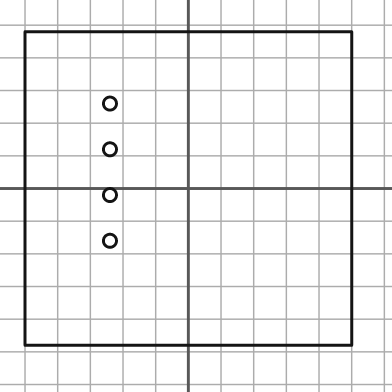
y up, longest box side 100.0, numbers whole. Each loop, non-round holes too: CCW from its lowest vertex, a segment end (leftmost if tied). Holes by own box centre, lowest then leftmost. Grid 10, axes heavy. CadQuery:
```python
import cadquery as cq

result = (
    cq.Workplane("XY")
    .moveTo(-50.0, -48.0)
    .lineTo(50.0, -48.0)
    .lineTo(50.0, 48.0)
    .lineTo(-50.0, 48.0)
    .close()
    .moveTo(-24.0, -16.0)
    .circle(2.0)
    .moveTo(-24.0, -2.0)
    .circle(2.0)
    .moveTo(-24.0, 12.0)
    .circle(2.0)
    .moveTo(-24.0, 26.0)
    .circle(2.0)
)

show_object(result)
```